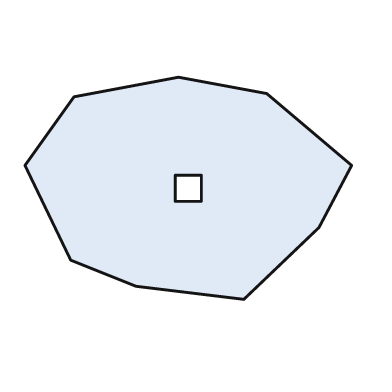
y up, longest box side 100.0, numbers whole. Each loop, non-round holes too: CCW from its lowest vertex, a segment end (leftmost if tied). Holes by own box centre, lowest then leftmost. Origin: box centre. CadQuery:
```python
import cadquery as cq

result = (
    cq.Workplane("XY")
    .moveTo(17.0, -34.0)
    .lineTo(40.0, -12.0)
    .lineTo(50.0, 7.0)
    .lineTo(24.0, 29.0)
    .lineTo(-3.0, 34.0)
    .lineTo(-35.0, 28.0)
    .lineTo(-50.0, 7.0)
    .lineTo(-36.0, -22.0)
    .lineTo(-16.0, -30.0)
    .close()
    .moveTo(-4.0, -4.0)
    .lineTo(4.0, -4.0)
    .lineTo(4.0, 4.0)
    .lineTo(-4.0, 4.0)
    .close()
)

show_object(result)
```